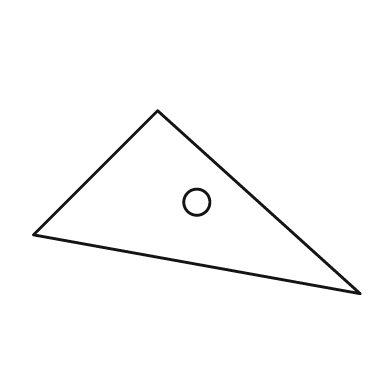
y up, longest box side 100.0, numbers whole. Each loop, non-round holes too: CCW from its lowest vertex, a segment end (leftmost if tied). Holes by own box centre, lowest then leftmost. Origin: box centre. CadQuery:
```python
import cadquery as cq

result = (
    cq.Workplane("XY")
    .moveTo(50.0, -28.0)
    .lineTo(-12.0, 28.0)
    .lineTo(-50.0, -10.0)
    .close()
    .moveTo(0.0, 0.0)
    .circle(4.0)
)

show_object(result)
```